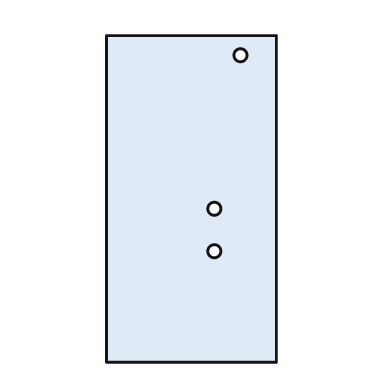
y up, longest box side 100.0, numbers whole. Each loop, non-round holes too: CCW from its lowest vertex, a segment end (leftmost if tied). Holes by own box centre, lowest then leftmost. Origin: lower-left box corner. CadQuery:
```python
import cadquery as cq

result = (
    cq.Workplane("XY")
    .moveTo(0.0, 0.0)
    .lineTo(52.0, 0.0)
    .lineTo(52.0, 100.0)
    .lineTo(0.0, 100.0)
    .close()
    .moveTo(33.0, 34.0)
    .circle(2.0)
    .moveTo(33.0, 47.0)
    .circle(2.0)
    .moveTo(41.0, 94.0)
    .circle(2.0)
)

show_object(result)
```